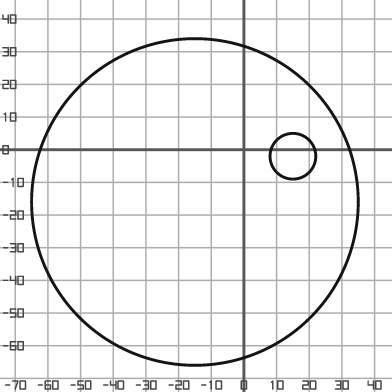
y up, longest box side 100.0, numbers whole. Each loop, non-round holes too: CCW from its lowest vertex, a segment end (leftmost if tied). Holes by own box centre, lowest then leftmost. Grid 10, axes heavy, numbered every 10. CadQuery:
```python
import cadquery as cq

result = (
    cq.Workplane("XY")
    .moveTo(-15.0, -16.0)
    .circle(50.0)
    .moveTo(15.0, -2.0)
    .circle(7.0)
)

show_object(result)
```